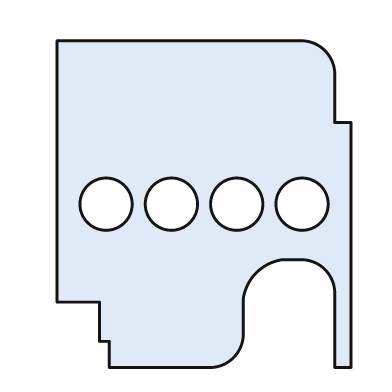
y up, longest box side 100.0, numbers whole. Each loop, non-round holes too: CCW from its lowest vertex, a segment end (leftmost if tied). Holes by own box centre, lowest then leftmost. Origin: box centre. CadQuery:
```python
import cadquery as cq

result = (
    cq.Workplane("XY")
    .moveTo(-29.0, -50.0)
    .lineTo(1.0, -50.0)
    .threePointArc((9.0, -47.0), (12.0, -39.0))
    .lineTo(12.0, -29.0)
    .threePointArc((16.0, -21.0), (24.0, -17.0))
    .lineTo(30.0, -17.0)
    .threePointArc((37.0, -20.0), (40.0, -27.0))
    .lineTo(40.0, -50.0)
    .lineTo(45.0, -50.0)
    .lineTo(45.0, 25.0)
    .lineTo(40.0, 25.0)
    .lineTo(40.0, 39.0)
    .threePointArc((37.0, 47.0), (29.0, 50.0))
    .lineTo(-45.0, 50.0)
    .lineTo(-45.0, -30.0)
    .lineTo(-32.0, -30.0)
    .lineTo(-32.0, -42.0)
    .lineTo(-29.0, -42.0)
    .close()
    .moveTo(-30.0, 0.0)
    .circle(8.0)
    .moveTo(-10.0, 0.0)
    .circle(8.0)
    .moveTo(10.0, 0.0)
    .circle(8.0)
    .moveTo(30.0, 0.0)
    .circle(8.0)
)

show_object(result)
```